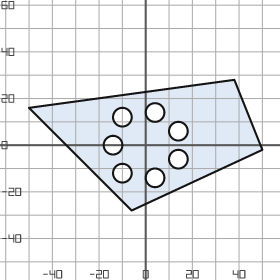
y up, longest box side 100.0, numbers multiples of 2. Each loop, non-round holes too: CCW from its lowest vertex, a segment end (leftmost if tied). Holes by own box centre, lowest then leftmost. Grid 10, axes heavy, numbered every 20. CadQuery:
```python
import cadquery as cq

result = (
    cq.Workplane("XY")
    .moveTo(-6.0, -28.0)
    .lineTo(50.0, -2.0)
    .lineTo(38.0, 28.0)
    .lineTo(-50.0, 16.0)
    .close()
    .moveTo(4.0, -14.0)
    .circle(4.0)
    .moveTo(-10.0, -12.0)
    .circle(4.0)
    .moveTo(14.0, -6.0)
    .circle(4.0)
    .moveTo(-14.0, 0.0)
    .circle(4.0)
    .moveTo(14.0, 6.0)
    .circle(4.0)
    .moveTo(-10.0, 12.0)
    .circle(4.0)
    .moveTo(4.0, 14.0)
    .circle(4.0)
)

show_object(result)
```